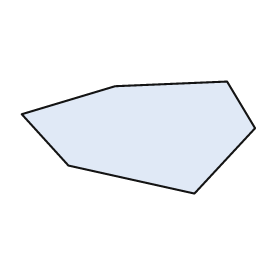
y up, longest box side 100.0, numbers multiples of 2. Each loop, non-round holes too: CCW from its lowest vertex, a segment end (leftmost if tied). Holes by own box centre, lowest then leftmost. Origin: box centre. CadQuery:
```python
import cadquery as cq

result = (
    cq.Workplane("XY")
    .moveTo(24.0, -24.0)
    .lineTo(50.0, 4.0)
    .lineTo(38.0, 24.0)
    .lineTo(-10.0, 22.0)
    .lineTo(-50.0, 10.0)
    .lineTo(-30.0, -12.0)
    .close()
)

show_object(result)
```